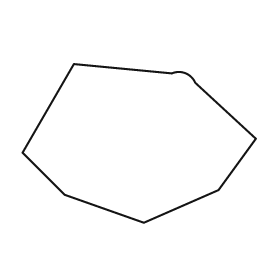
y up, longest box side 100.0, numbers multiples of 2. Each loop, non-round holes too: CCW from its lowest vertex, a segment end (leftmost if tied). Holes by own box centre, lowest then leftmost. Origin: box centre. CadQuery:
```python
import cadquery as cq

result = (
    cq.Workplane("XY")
    .moveTo(2.0, -34.0)
    .lineTo(34.0, -20.0)
    .lineTo(50.0, 2.0)
    .lineTo(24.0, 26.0)
    .threePointArc((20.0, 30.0), (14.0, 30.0))
    .lineTo(-28.0, 34.0)
    .lineTo(-50.0, -4.0)
    .lineTo(-32.0, -22.0)
    .close()
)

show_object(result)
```